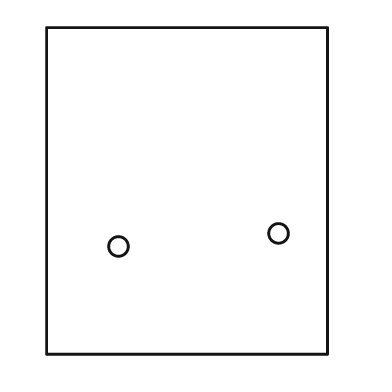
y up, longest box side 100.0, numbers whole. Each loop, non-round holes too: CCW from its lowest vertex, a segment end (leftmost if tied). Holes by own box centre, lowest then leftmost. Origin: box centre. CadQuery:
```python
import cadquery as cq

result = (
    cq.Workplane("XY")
    .moveTo(-43.0, -50.0)
    .lineTo(43.0, -50.0)
    .lineTo(43.0, 50.0)
    .lineTo(-43.0, 50.0)
    .close()
    .moveTo(-21.0, -17.0)
    .circle(3.0)
    .moveTo(28.0, -13.0)
    .circle(3.0)
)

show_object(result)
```